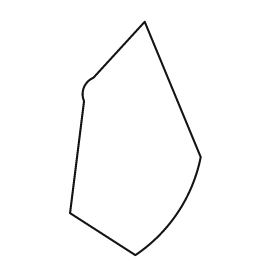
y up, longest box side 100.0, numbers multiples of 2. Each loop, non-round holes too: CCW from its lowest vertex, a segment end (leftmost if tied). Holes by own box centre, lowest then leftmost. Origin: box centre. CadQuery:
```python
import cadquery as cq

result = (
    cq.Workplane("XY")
    .moveTo(0.0, -50.0)
    .threePointArc((18.0, -32.0), (28.0, -8.0))
    .lineTo(4.0, 50.0)
    .lineTo(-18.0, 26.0)
    .threePointArc((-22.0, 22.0), (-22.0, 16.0))
    .lineTo(-28.0, -32.0)
    .close()
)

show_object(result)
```